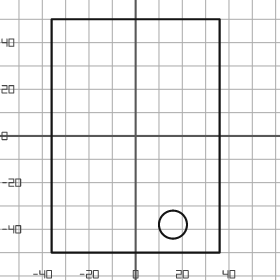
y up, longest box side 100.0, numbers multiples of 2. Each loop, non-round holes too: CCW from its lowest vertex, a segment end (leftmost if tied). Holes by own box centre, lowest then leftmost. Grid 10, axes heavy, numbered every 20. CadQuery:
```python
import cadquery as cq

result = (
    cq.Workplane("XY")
    .moveTo(-36.0, -50.0)
    .lineTo(36.0, -50.0)
    .lineTo(36.0, 50.0)
    .lineTo(-36.0, 50.0)
    .close()
    .moveTo(16.0, -38.0)
    .circle(6.0)
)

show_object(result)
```